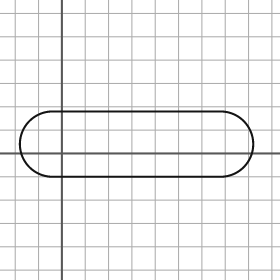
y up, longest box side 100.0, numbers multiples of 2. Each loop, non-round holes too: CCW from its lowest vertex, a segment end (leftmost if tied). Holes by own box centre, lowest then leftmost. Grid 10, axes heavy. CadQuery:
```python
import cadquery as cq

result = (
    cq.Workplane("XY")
    .moveTo(-4.0, -10.0)
    .lineTo(68.0, -10.0)
    .threePointArc((82.0, 4.0), (68.0, 18.0))
    .lineTo(-4.0, 18.0)
    .threePointArc((-18.0, 4.0), (-4.0, -10.0))
    .close()
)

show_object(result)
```